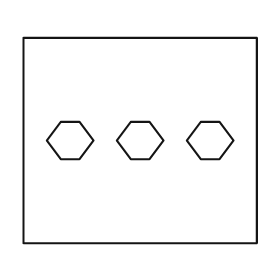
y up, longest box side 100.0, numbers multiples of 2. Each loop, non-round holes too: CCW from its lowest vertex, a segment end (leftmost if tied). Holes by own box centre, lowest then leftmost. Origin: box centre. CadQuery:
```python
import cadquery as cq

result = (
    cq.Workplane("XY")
    .moveTo(-50.0, -44.0)
    .lineTo(50.0, -44.0)
    .lineTo(50.0, 44.0)
    .lineTo(-50.0, 44.0)
    .close()
    .moveTo(-34.0, -8.0)
    .lineTo(-26.0, -8.0)
    .lineTo(-20.0, 0.0)
    .lineTo(-26.0, 8.0)
    .lineTo(-34.0, 8.0)
    .lineTo(-40.0, 0.0)
    .close()
    .moveTo(-4.0, -8.0)
    .lineTo(4.0, -8.0)
    .lineTo(10.0, 0.0)
    .lineTo(4.0, 8.0)
    .lineTo(-4.0, 8.0)
    .lineTo(-10.0, 0.0)
    .close()
    .moveTo(26.0, -8.0)
    .lineTo(34.0, -8.0)
    .lineTo(40.0, 0.0)
    .lineTo(34.0, 8.0)
    .lineTo(26.0, 8.0)
    .lineTo(20.0, 0.0)
    .close()
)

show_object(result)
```